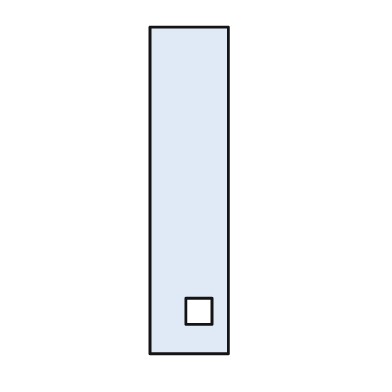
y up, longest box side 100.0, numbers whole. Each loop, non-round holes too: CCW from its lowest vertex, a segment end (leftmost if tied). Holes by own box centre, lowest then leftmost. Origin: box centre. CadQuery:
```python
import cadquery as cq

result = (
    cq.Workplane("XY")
    .moveTo(-12.0, -50.0)
    .lineTo(12.0, -50.0)
    .lineTo(12.0, 50.0)
    .lineTo(-12.0, 50.0)
    .close()
    .moveTo(-1.0, -41.0)
    .lineTo(7.0, -41.0)
    .lineTo(7.0, -33.0)
    .lineTo(-1.0, -33.0)
    .close()
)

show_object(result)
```